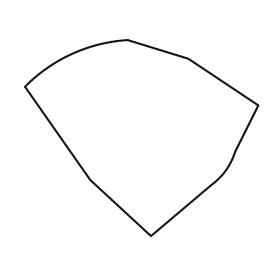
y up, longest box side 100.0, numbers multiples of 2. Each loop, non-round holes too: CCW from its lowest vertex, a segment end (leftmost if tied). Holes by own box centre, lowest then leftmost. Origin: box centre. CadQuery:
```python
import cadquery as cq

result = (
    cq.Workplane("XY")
    .moveTo(4.0, -42.0)
    .lineTo(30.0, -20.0)
    .threePointArc((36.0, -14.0), (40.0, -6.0))
    .lineTo(50.0, 14.0)
    .lineTo(20.0, 34.0)
    .lineTo(-6.0, 42.0)
    .threePointArc((-30.0, 36.0), (-50.0, 22.0))
    .lineTo(-22.0, -18.0)
    .close()
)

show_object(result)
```